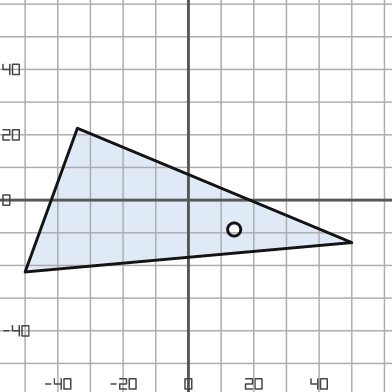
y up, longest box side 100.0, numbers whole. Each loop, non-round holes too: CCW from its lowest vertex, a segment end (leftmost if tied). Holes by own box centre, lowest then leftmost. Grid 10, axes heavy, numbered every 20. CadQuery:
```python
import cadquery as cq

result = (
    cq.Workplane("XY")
    .moveTo(-50.0, -22.0)
    .lineTo(50.0, -13.0)
    .lineTo(-34.0, 22.0)
    .close()
    .moveTo(14.0, -9.0)
    .circle(2.0)
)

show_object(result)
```